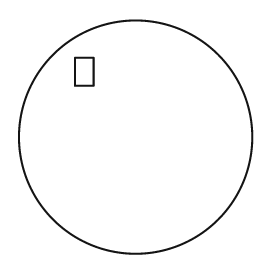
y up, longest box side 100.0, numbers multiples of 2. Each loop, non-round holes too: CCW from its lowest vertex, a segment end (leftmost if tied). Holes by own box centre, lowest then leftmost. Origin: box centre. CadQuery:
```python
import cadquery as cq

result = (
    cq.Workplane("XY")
    .moveTo(0.0, 0.0)
    .circle(50.0)
    .moveTo(-26.0, 22.0)
    .lineTo(-18.0, 22.0)
    .lineTo(-18.0, 34.0)
    .lineTo(-26.0, 34.0)
    .close()
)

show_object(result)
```